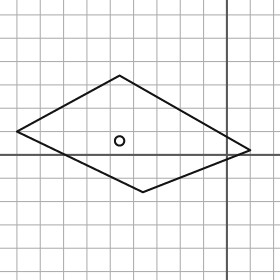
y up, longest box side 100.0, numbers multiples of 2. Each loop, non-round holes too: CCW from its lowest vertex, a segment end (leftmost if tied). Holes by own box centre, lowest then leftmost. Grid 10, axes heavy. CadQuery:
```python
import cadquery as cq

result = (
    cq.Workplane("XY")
    .moveTo(-36.0, -16.0)
    .lineTo(10.0, 2.0)
    .lineTo(-46.0, 34.0)
    .lineTo(-90.0, 10.0)
    .close()
    .moveTo(-46.0, 6.0)
    .circle(2.0)
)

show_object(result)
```